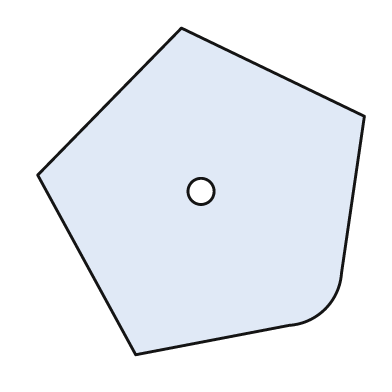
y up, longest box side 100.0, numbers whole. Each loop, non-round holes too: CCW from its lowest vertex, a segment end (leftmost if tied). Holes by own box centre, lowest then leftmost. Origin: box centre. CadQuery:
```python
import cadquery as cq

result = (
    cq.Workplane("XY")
    .moveTo(-20.0, -50.0)
    .lineTo(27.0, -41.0)
    .threePointArc((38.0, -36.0), (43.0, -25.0))
    .lineTo(50.0, 23.0)
    .lineTo(-6.0, 50.0)
    .lineTo(-50.0, 5.0)
    .close()
    .moveTo(0.0, 0.0)
    .circle(4.0)
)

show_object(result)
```